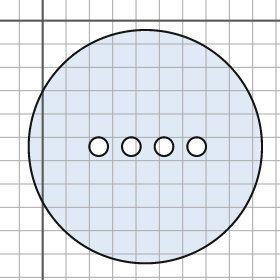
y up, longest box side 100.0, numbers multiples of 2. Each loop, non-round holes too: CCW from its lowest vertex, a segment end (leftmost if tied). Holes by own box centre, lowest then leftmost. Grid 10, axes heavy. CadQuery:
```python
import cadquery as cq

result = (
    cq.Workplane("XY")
    .moveTo(44.0, -54.0)
    .circle(50.0)
    .moveTo(24.0, -54.0)
    .circle(4.0)
    .moveTo(38.0, -54.0)
    .circle(4.0)
    .moveTo(52.0, -54.0)
    .circle(4.0)
    .moveTo(66.0, -54.0)
    .circle(4.0)
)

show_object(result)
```